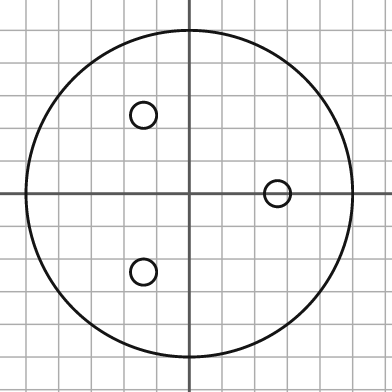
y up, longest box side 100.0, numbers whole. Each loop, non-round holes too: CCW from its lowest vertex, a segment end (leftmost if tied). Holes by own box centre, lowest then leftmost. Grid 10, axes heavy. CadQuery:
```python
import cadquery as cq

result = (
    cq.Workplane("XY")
    .moveTo(0.0, 0.0)
    .circle(50.0)
    .moveTo(-14.0, -24.0)
    .circle(4.0)
    .moveTo(27.0, 0.0)
    .circle(4.0)
    .moveTo(-14.0, 24.0)
    .circle(4.0)
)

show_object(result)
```